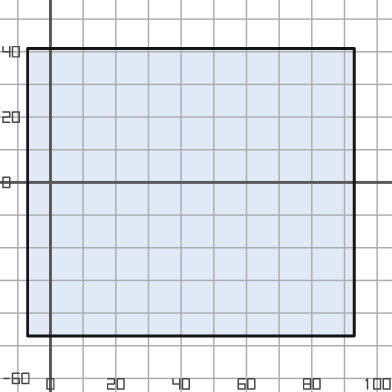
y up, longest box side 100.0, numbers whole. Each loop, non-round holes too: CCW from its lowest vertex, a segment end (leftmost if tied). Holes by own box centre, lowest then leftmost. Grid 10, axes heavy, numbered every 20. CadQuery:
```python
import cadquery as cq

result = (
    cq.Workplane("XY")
    .moveTo(-7.0, -47.0)
    .lineTo(93.0, -47.0)
    .lineTo(93.0, 41.0)
    .lineTo(-7.0, 41.0)
    .close()
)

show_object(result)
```